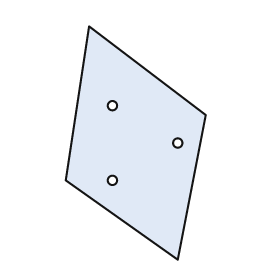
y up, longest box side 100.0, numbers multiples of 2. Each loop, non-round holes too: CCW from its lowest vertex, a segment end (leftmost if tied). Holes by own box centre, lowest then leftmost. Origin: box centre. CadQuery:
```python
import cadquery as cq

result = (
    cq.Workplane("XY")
    .moveTo(18.0, -50.0)
    .lineTo(30.0, 12.0)
    .lineTo(-20.0, 50.0)
    .lineTo(-30.0, -16.0)
    .close()
    .moveTo(-10.0, -16.0)
    .circle(2.0)
    .moveTo(18.0, 0.0)
    .circle(2.0)
    .moveTo(-10.0, 16.0)
    .circle(2.0)
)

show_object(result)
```